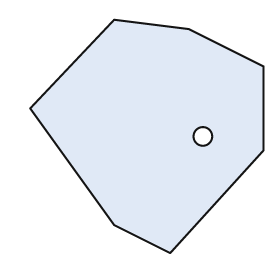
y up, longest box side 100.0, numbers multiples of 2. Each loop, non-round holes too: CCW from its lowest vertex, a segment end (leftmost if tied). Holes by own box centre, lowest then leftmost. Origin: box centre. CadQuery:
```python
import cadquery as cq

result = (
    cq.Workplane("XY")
    .moveTo(10.0, -50.0)
    .lineTo(50.0, -6.0)
    .lineTo(50.0, 30.0)
    .lineTo(18.0, 46.0)
    .lineTo(-14.0, 50.0)
    .lineTo(-50.0, 12.0)
    .lineTo(-14.0, -38.0)
    .close()
    .moveTo(24.0, 0.0)
    .circle(4.0)
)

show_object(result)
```